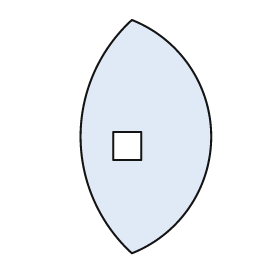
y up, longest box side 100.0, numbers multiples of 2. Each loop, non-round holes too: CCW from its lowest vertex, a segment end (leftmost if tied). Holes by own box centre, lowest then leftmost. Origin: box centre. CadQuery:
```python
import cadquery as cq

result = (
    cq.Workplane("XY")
    .moveTo(-6.0, -50.0)
    .threePointArc((28.0, 0.0), (-6.0, 50.0))
    .threePointArc((-28.0, 0.0), (-6.0, -50.0))
    .close()
    .moveTo(-14.0, -10.0)
    .lineTo(-2.0, -10.0)
    .lineTo(-2.0, 2.0)
    .lineTo(-14.0, 2.0)
    .close()
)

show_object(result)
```